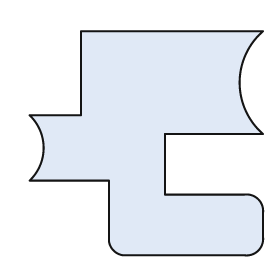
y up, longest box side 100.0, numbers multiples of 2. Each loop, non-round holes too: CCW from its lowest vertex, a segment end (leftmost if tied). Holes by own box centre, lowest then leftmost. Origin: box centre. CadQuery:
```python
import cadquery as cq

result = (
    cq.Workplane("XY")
    .moveTo(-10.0, -48.0)
    .lineTo(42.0, -48.0)
    .threePointArc((48.0, -46.0), (50.0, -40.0))
    .lineTo(50.0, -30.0)
    .threePointArc((48.0, -24.0), (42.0, -22.0))
    .lineTo(8.0, -22.0)
    .lineTo(8.0, 4.0)
    .lineTo(50.0, 4.0)
    .threePointArc((40.0, 26.0), (50.0, 48.0))
    .lineTo(-28.0, 48.0)
    .lineTo(-28.0, 12.0)
    .lineTo(-50.0, 12.0)
    .threePointArc((-44.0, -2.0), (-50.0, -16.0))
    .lineTo(-16.0, -16.0)
    .lineTo(-16.0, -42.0)
    .threePointArc((-14.0, -46.0), (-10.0, -48.0))
    .close()
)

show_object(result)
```